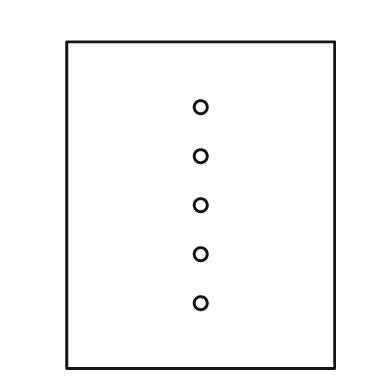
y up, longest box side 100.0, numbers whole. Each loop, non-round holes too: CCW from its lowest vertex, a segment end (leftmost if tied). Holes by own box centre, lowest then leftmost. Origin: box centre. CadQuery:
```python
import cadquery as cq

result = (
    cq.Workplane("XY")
    .moveTo(-41.0, -50.0)
    .lineTo(41.0, -50.0)
    .lineTo(41.0, 50.0)
    .lineTo(-41.0, 50.0)
    .close()
    .moveTo(0.0, -30.0)
    .circle(2.0)
    .moveTo(0.0, -15.0)
    .circle(2.0)
    .moveTo(0.0, 0.0)
    .circle(2.0)
    .moveTo(0.0, 15.0)
    .circle(2.0)
    .moveTo(0.0, 30.0)
    .circle(2.0)
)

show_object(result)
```